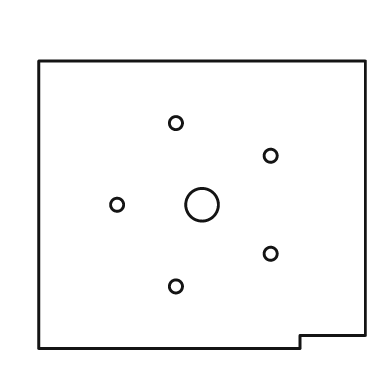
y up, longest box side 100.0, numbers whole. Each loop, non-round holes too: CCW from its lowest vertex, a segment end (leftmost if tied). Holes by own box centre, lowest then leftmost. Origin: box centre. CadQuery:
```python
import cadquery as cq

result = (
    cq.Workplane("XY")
    .moveTo(-50.0, -44.0)
    .lineTo(30.0, -44.0)
    .lineTo(30.0, -40.0)
    .lineTo(50.0, -40.0)
    .lineTo(50.0, 44.0)
    .lineTo(-50.0, 44.0)
    .close()
    .moveTo(-8.0, -25.0)
    .circle(2.0)
    .moveTo(21.0, -15.0)
    .circle(2.0)
    .moveTo(-26.0, 0.0)
    .circle(2.0)
    .moveTo(0.0, 0.0)
    .circle(5.0)
    .moveTo(21.0, 15.0)
    .circle(2.0)
    .moveTo(-8.0, 25.0)
    .circle(2.0)
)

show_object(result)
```